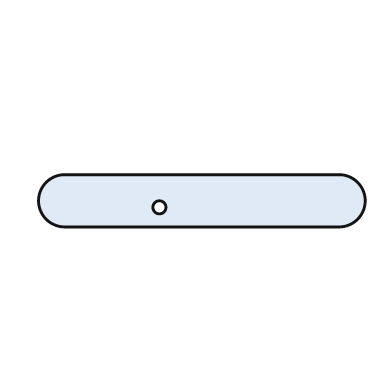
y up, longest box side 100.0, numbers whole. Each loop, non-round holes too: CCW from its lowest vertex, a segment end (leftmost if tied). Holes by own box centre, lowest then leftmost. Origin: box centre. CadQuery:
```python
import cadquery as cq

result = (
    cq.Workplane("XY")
    .moveTo(-42.0, -8.0)
    .lineTo(42.0, -8.0)
    .threePointArc((50.0, 0.0), (42.0, 8.0))
    .lineTo(-42.0, 8.0)
    .threePointArc((-50.0, 0.0), (-42.0, -8.0))
    .close()
    .moveTo(-13.0, -2.0)
    .circle(2.0)
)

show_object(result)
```